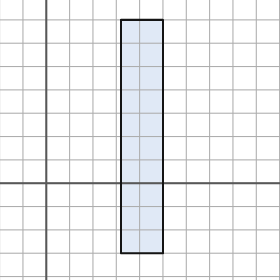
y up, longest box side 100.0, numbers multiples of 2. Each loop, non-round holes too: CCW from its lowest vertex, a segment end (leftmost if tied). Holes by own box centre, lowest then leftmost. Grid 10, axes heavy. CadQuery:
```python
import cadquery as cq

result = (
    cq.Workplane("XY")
    .moveTo(32.0, -30.0)
    .lineTo(50.0, -30.0)
    .lineTo(50.0, 70.0)
    .lineTo(32.0, 70.0)
    .close()
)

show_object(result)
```